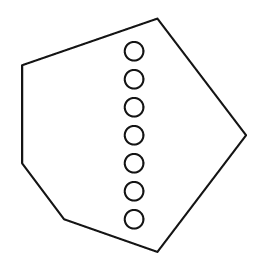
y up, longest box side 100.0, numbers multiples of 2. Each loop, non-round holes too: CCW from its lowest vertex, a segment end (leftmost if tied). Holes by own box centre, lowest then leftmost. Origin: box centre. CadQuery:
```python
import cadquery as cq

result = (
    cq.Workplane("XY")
    .moveTo(10.0, -50.0)
    .lineTo(48.0, 0.0)
    .lineTo(10.0, 50.0)
    .lineTo(-48.0, 30.0)
    .lineTo(-48.0, -12.0)
    .lineTo(-30.0, -36.0)
    .close()
    .moveTo(0.0, -36.0)
    .circle(4.0)
    .moveTo(0.0, -24.0)
    .circle(4.0)
    .moveTo(0.0, -12.0)
    .circle(4.0)
    .moveTo(0.0, 0.0)
    .circle(4.0)
    .moveTo(0.0, 12.0)
    .circle(4.0)
    .moveTo(0.0, 24.0)
    .circle(4.0)
    .moveTo(0.0, 36.0)
    .circle(4.0)
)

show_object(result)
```